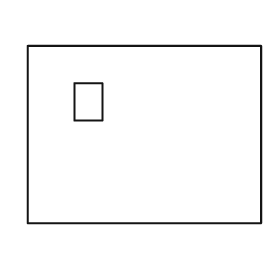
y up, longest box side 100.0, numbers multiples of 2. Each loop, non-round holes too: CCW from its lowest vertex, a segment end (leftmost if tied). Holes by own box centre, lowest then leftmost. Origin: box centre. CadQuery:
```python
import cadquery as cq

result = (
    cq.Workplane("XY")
    .moveTo(-50.0, -38.0)
    .lineTo(50.0, -38.0)
    .lineTo(50.0, 38.0)
    .lineTo(-50.0, 38.0)
    .close()
    .moveTo(-30.0, 6.0)
    .lineTo(-18.0, 6.0)
    .lineTo(-18.0, 22.0)
    .lineTo(-30.0, 22.0)
    .close()
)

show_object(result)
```